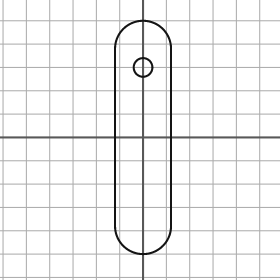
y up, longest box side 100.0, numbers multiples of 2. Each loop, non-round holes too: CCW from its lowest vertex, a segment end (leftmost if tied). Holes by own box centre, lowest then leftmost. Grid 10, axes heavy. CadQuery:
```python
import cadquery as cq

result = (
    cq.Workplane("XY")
    .moveTo(-12.0, -38.0)
    .threePointArc((0.0, -50.0), (12.0, -38.0))
    .lineTo(12.0, 38.0)
    .threePointArc((0.0, 50.0), (-12.0, 38.0))
    .close()
    .moveTo(0.0, 30.0)
    .circle(4.0)
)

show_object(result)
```